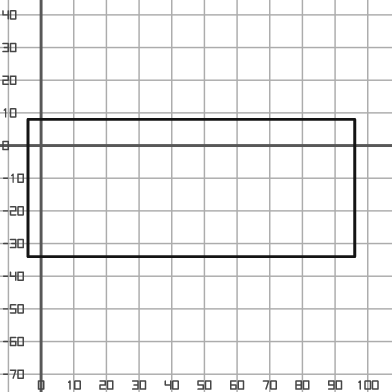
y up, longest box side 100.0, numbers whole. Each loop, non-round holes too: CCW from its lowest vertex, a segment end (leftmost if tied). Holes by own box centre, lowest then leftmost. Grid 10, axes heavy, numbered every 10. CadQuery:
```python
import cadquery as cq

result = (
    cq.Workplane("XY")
    .moveTo(-4.0, -34.0)
    .lineTo(96.0, -34.0)
    .lineTo(96.0, 8.0)
    .lineTo(-4.0, 8.0)
    .close()
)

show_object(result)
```